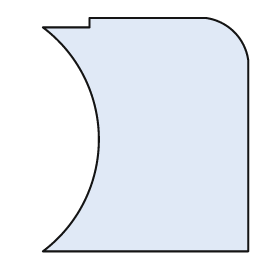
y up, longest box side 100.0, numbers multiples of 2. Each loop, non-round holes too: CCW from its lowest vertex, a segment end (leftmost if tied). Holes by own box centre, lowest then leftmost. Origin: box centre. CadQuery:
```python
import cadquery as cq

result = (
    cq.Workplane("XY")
    .moveTo(-44.0, -50.0)
    .lineTo(44.0, -50.0)
    .lineTo(44.0, 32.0)
    .threePointArc((38.0, 44.0), (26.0, 50.0))
    .lineTo(-24.0, 50.0)
    .lineTo(-24.0, 46.0)
    .lineTo(-44.0, 46.0)
    .threePointArc((-20.0, -2.0), (-44.0, -50.0))
    .close()
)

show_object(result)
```